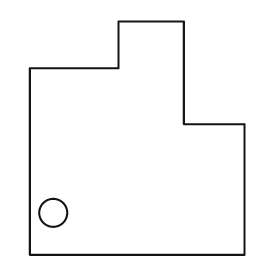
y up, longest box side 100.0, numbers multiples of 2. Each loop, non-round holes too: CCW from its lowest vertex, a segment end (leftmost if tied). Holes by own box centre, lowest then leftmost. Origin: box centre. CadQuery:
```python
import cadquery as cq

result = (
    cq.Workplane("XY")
    .moveTo(-46.0, -50.0)
    .lineTo(46.0, -50.0)
    .lineTo(46.0, 6.0)
    .lineTo(20.0, 6.0)
    .lineTo(20.0, 50.0)
    .lineTo(-8.0, 50.0)
    .lineTo(-8.0, 30.0)
    .lineTo(-46.0, 30.0)
    .close()
    .moveTo(-36.0, -32.0)
    .circle(6.0)
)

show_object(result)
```